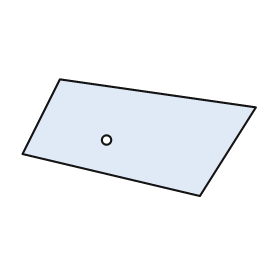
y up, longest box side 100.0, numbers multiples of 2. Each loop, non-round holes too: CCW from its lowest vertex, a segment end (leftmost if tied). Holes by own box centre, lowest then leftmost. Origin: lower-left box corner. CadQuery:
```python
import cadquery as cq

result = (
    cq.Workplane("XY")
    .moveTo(76.0, 0.0)
    .lineTo(100.0, 38.0)
    .lineTo(16.0, 50.0)
    .lineTo(0.0, 18.0)
    .close()
    .moveTo(36.0, 24.0)
    .circle(2.0)
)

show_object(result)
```